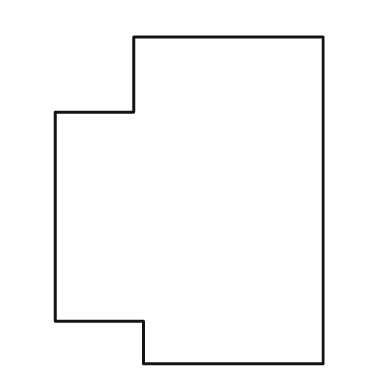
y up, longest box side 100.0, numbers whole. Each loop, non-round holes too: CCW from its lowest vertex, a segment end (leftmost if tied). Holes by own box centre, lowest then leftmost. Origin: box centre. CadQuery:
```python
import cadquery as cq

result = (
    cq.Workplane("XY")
    .moveTo(-14.0, -50.0)
    .lineTo(41.0, -50.0)
    .lineTo(41.0, 50.0)
    .lineTo(-17.0, 50.0)
    .lineTo(-17.0, 27.0)
    .lineTo(-41.0, 27.0)
    .lineTo(-41.0, -37.0)
    .lineTo(-14.0, -37.0)
    .close()
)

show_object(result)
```